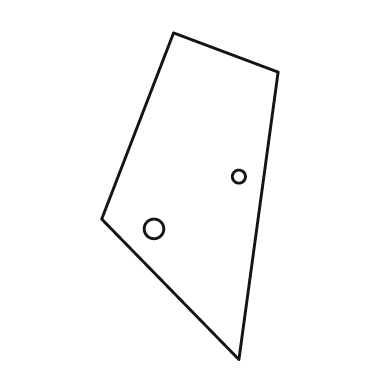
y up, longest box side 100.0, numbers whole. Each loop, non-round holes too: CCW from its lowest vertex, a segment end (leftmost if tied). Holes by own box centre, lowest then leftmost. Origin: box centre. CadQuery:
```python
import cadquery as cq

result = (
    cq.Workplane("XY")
    .moveTo(15.0, -50.0)
    .lineTo(27.0, 38.0)
    .lineTo(-5.0, 50.0)
    .lineTo(-27.0, -7.0)
    .close()
    .moveTo(-11.0, -10.0)
    .circle(3.0)
    .moveTo(15.0, 6.0)
    .circle(2.0)
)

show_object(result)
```